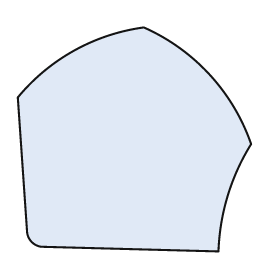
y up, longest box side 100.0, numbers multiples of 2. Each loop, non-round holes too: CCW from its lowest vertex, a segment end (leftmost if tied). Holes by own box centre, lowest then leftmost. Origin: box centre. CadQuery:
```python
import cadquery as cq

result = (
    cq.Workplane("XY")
    .moveTo(36.0, -48.0)
    .threePointArc((40.0, -24.0), (50.0, -2.0))
    .threePointArc((32.0, 28.0), (4.0, 48.0))
    .threePointArc((-26.0, 38.0), (-50.0, 18.0))
    .lineTo(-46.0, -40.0)
    .threePointArc((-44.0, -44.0), (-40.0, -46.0))
    .close()
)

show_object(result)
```